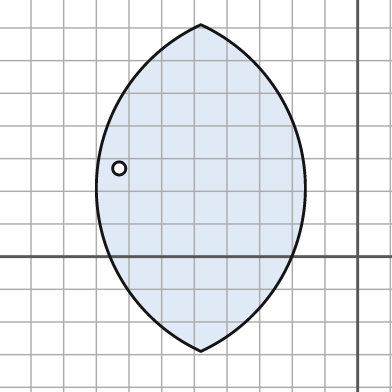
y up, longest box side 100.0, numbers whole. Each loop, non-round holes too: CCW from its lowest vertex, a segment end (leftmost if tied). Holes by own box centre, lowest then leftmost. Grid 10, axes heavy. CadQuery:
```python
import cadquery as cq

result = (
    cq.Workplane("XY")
    .moveTo(-48.0, -29.0)
    .threePointArc((-16.0, 21.0), (-48.0, 71.0))
    .threePointArc((-80.0, 21.0), (-48.0, -29.0))
    .close()
    .moveTo(-73.0, 27.0)
    .circle(2.0)
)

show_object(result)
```